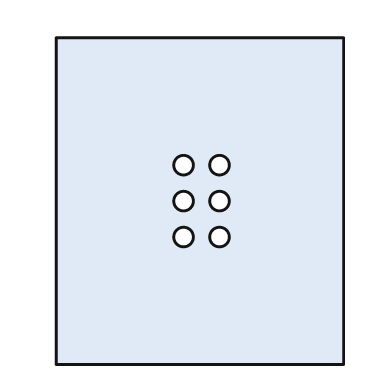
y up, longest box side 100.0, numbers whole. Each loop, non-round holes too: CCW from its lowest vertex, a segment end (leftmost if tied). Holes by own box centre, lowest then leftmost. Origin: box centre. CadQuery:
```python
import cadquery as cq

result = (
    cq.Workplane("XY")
    .moveTo(-44.0, -50.0)
    .lineTo(44.0, -50.0)
    .lineTo(44.0, 50.0)
    .lineTo(-44.0, 50.0)
    .close()
    .moveTo(-5.0, -11.0)
    .circle(3.0)
    .moveTo(6.0, -11.0)
    .circle(3.0)
    .moveTo(-5.0, 0.0)
    .circle(3.0)
    .moveTo(6.0, 0.0)
    .circle(3.0)
    .moveTo(-5.0, 11.0)
    .circle(3.0)
    .moveTo(6.0, 11.0)
    .circle(3.0)
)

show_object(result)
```